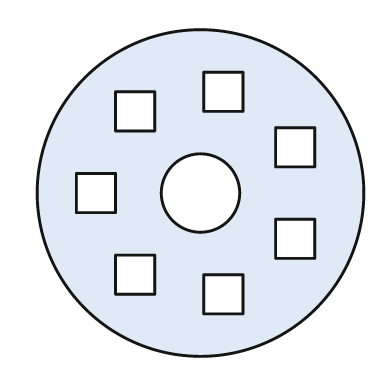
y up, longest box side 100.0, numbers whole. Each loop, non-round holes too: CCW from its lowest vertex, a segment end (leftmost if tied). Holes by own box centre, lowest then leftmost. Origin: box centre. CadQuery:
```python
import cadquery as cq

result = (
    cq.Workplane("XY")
    .moveTo(0.0, 0.0)
    .circle(50.0)
    .moveTo(1.0, -37.0)
    .lineTo(13.0, -37.0)
    .lineTo(13.0, -25.0)
    .lineTo(1.0, -25.0)
    .close()
    .moveTo(-26.0, -31.0)
    .lineTo(-14.0, -31.0)
    .lineTo(-14.0, -19.0)
    .lineTo(-26.0, -19.0)
    .close()
    .moveTo(23.0, -20.0)
    .lineTo(35.0, -20.0)
    .lineTo(35.0, -8.0)
    .lineTo(23.0, -8.0)
    .close()
    .moveTo(-38.0, -6.0)
    .lineTo(-26.0, -6.0)
    .lineTo(-26.0, 6.0)
    .lineTo(-38.0, 6.0)
    .close()
    .moveTo(0.0, 0.0)
    .circle(12.0)
    .moveTo(23.0, 8.0)
    .lineTo(35.0, 8.0)
    .lineTo(35.0, 20.0)
    .lineTo(23.0, 20.0)
    .close()
    .moveTo(-26.0, 19.0)
    .lineTo(-14.0, 19.0)
    .lineTo(-14.0, 31.0)
    .lineTo(-26.0, 31.0)
    .close()
    .moveTo(1.0, 25.0)
    .lineTo(13.0, 25.0)
    .lineTo(13.0, 37.0)
    .lineTo(1.0, 37.0)
    .close()
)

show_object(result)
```